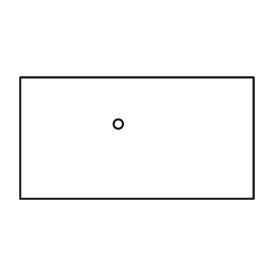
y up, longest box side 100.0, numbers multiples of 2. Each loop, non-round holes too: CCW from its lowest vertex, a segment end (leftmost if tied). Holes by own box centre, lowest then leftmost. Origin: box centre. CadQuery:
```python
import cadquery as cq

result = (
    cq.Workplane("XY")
    .moveTo(-50.0, -26.0)
    .lineTo(50.0, -26.0)
    .lineTo(50.0, 26.0)
    .lineTo(-50.0, 26.0)
    .close()
    .moveTo(-8.0, 6.0)
    .circle(2.0)
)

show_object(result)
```